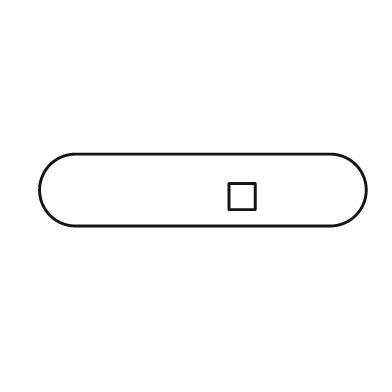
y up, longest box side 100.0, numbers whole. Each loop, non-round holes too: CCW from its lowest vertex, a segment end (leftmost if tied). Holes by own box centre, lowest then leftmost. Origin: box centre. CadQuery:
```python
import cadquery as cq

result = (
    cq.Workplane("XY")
    .moveTo(-39.0, -11.0)
    .lineTo(39.0, -11.0)
    .threePointArc((50.0, 0.0), (39.0, 11.0))
    .lineTo(-39.0, 11.0)
    .threePointArc((-50.0, 0.0), (-39.0, -11.0))
    .close()
    .moveTo(8.0, -6.0)
    .lineTo(16.0, -6.0)
    .lineTo(16.0, 2.0)
    .lineTo(8.0, 2.0)
    .close()
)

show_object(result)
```